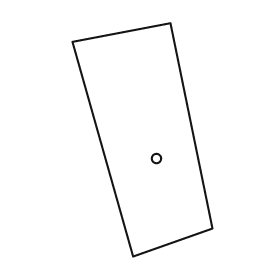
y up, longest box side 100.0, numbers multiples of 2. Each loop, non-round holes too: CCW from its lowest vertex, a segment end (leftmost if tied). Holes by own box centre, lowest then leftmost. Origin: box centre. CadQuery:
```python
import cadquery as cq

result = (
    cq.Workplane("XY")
    .moveTo(-4.0, -50.0)
    .lineTo(30.0, -38.0)
    .lineTo(12.0, 50.0)
    .lineTo(-30.0, 42.0)
    .close()
    .moveTo(6.0, -8.0)
    .circle(2.0)
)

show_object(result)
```